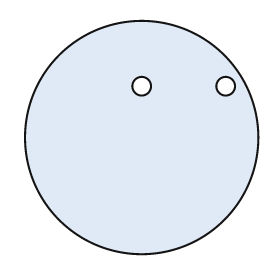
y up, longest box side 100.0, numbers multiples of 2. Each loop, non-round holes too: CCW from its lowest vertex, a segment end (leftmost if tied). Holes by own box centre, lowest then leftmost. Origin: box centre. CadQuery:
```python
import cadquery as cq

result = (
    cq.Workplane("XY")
    .moveTo(0.0, 0.0)
    .circle(50.0)
    .moveTo(0.0, 22.0)
    .circle(4.0)
    .moveTo(36.0, 22.0)
    .circle(4.0)
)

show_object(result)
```